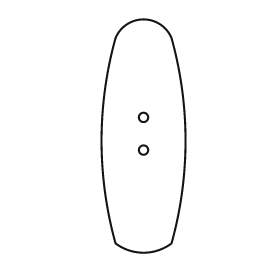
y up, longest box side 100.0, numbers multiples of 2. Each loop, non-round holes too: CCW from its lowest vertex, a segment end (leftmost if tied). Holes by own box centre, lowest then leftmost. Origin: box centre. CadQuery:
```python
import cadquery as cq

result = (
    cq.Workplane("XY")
    .moveTo(-12.0, -46.0)
    .threePointArc((0.0, -50.0), (12.0, -46.0))
    .threePointArc((18.0, -2.0), (12.0, 42.0))
    .threePointArc((0.0, 50.0), (-12.0, 42.0))
    .threePointArc((-18.0, -2.0), (-12.0, -46.0))
    .close()
    .moveTo(0.0, -6.0)
    .circle(2.0)
    .moveTo(0.0, 8.0)
    .circle(2.0)
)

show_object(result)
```